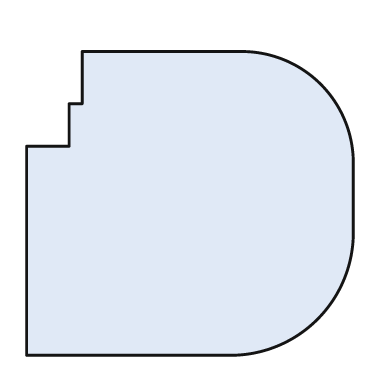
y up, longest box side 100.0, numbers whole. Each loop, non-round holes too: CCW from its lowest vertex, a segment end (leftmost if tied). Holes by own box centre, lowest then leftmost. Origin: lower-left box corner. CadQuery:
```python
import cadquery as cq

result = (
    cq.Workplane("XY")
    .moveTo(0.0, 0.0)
    .lineTo(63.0, 0.0)
    .threePointArc((89.0, 11.0), (100.0, 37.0))
    .lineTo(100.0, 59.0)
    .threePointArc((90.0, 83.0), (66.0, 93.0))
    .lineTo(17.0, 93.0)
    .lineTo(17.0, 77.0)
    .lineTo(13.0, 77.0)
    .lineTo(13.0, 64.0)
    .lineTo(0.0, 64.0)
    .close()
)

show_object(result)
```